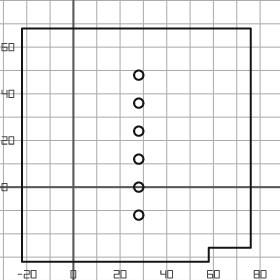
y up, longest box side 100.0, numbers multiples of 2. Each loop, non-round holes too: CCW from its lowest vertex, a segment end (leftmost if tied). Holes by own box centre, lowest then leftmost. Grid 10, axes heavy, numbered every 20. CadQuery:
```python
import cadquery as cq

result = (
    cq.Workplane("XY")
    .moveTo(-22.0, -32.0)
    .lineTo(58.0, -32.0)
    .lineTo(58.0, -26.0)
    .lineTo(76.0, -26.0)
    .lineTo(76.0, 68.0)
    .lineTo(-22.0, 68.0)
    .close()
    .moveTo(28.0, -12.0)
    .circle(2.0)
    .moveTo(28.0, 0.0)
    .circle(2.0)
    .moveTo(28.0, 12.0)
    .circle(2.0)
    .moveTo(28.0, 24.0)
    .circle(2.0)
    .moveTo(28.0, 36.0)
    .circle(2.0)
    .moveTo(28.0, 48.0)
    .circle(2.0)
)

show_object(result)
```